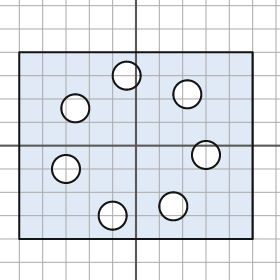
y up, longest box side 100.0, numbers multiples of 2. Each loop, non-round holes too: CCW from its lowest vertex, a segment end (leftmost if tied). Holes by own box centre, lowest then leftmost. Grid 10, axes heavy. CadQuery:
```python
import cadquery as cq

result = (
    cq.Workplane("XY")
    .moveTo(-50.0, -40.0)
    .lineTo(50.0, -40.0)
    .lineTo(50.0, 40.0)
    .lineTo(-50.0, 40.0)
    .close()
    .moveTo(-10.0, -30.0)
    .circle(6.0)
    .moveTo(16.0, -26.0)
    .circle(6.0)
    .moveTo(-30.0, -10.0)
    .circle(6.0)
    .moveTo(30.0, -4.0)
    .circle(6.0)
    .moveTo(-26.0, 16.0)
    .circle(6.0)
    .moveTo(22.0, 22.0)
    .circle(6.0)
    .moveTo(-4.0, 30.0)
    .circle(6.0)
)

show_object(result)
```